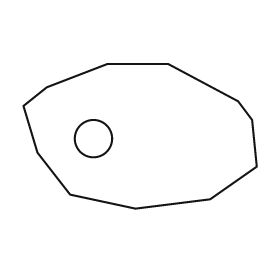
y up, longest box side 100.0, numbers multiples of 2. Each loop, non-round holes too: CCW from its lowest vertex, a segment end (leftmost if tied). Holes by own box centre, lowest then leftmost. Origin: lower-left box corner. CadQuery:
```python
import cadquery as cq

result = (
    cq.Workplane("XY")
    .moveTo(48.0, 0.0)
    .lineTo(80.0, 4.0)
    .lineTo(100.0, 18.0)
    .lineTo(98.0, 38.0)
    .lineTo(92.0, 46.0)
    .lineTo(62.0, 62.0)
    .lineTo(36.0, 62.0)
    .lineTo(10.0, 52.0)
    .lineTo(0.0, 44.0)
    .lineTo(6.0, 24.0)
    .lineTo(20.0, 6.0)
    .close()
    .moveTo(30.0, 30.0)
    .circle(8.0)
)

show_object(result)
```